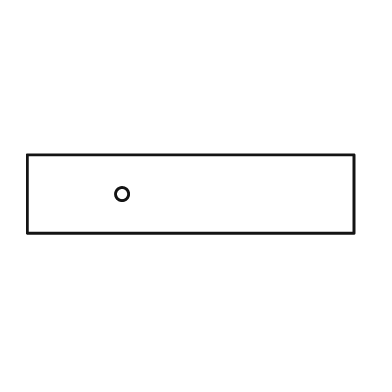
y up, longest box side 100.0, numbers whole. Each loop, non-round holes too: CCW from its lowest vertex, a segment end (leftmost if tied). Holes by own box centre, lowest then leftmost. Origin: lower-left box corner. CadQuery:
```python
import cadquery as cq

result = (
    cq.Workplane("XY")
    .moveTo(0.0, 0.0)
    .lineTo(100.0, 0.0)
    .lineTo(100.0, 24.0)
    .lineTo(0.0, 24.0)
    .close()
    .moveTo(29.0, 12.0)
    .circle(2.0)
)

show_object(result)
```